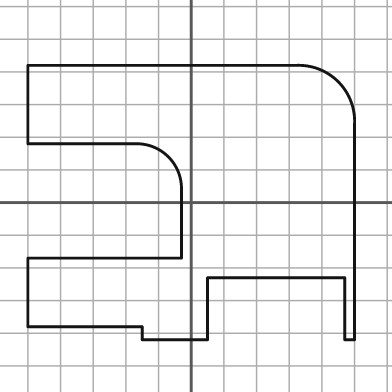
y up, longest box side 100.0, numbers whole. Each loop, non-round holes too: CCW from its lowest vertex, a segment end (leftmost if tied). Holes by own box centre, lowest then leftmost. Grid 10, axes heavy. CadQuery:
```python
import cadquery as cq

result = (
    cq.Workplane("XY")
    .moveTo(-15.0, -42.0)
    .lineTo(5.0, -42.0)
    .lineTo(5.0, -23.0)
    .lineTo(47.0, -23.0)
    .lineTo(47.0, -42.0)
    .lineTo(50.0, -42.0)
    .lineTo(50.0, 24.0)
    .threePointArc((45.0, 37.0), (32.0, 42.0))
    .lineTo(-50.0, 42.0)
    .lineTo(-50.0, 18.0)
    .lineTo(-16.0, 18.0)
    .threePointArc((-7.0, 14.0), (-3.0, 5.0))
    .lineTo(-3.0, -17.0)
    .lineTo(-50.0, -17.0)
    .lineTo(-50.0, -38.0)
    .lineTo(-15.0, -38.0)
    .close()
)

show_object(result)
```